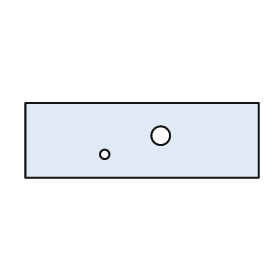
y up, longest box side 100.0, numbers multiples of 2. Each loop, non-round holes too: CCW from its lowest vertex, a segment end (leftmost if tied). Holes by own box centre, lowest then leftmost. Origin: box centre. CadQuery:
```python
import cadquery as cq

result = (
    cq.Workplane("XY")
    .moveTo(-50.0, -16.0)
    .lineTo(50.0, -16.0)
    .lineTo(50.0, 16.0)
    .lineTo(-50.0, 16.0)
    .close()
    .moveTo(-16.0, -6.0)
    .circle(2.0)
    .moveTo(8.0, 2.0)
    .circle(4.0)
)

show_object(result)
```